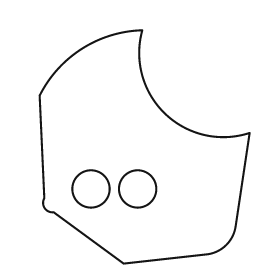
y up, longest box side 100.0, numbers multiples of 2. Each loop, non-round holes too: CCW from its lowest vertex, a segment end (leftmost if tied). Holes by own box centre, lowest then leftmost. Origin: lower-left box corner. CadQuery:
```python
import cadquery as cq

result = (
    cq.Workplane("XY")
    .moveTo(36.0, 0.0)
    .lineTo(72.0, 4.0)
    .threePointArc((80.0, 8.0), (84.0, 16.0))
    .lineTo(90.0, 56.0)
    .threePointArc((54.0, 64.0), (44.0, 100.0))
    .threePointArc((18.0, 92.0), (0.0, 72.0))
    .lineTo(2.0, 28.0)
    .threePointArc((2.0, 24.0), (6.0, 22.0))
    .close()
    .moveTo(22.0, 32.0)
    .circle(8.0)
    .moveTo(42.0, 32.0)
    .circle(8.0)
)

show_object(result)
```